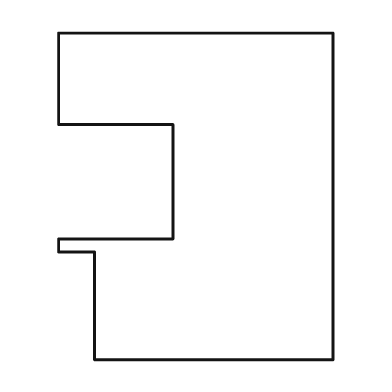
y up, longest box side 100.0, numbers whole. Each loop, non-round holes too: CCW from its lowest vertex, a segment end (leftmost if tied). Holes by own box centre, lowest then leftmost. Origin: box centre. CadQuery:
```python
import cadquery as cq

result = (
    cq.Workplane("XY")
    .moveTo(-31.0, -50.0)
    .lineTo(42.0, -50.0)
    .lineTo(42.0, 50.0)
    .lineTo(-42.0, 50.0)
    .lineTo(-42.0, 22.0)
    .lineTo(-7.0, 22.0)
    .lineTo(-7.0, -13.0)
    .lineTo(-42.0, -13.0)
    .lineTo(-42.0, -17.0)
    .lineTo(-31.0, -17.0)
    .close()
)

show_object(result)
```